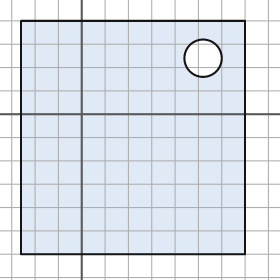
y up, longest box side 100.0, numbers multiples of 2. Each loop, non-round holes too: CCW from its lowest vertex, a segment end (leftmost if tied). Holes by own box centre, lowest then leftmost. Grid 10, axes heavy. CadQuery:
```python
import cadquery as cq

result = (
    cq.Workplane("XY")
    .moveTo(-26.0, -60.0)
    .lineTo(70.0, -60.0)
    .lineTo(70.0, 40.0)
    .lineTo(-26.0, 40.0)
    .close()
    .moveTo(52.0, 24.0)
    .circle(8.0)
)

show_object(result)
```